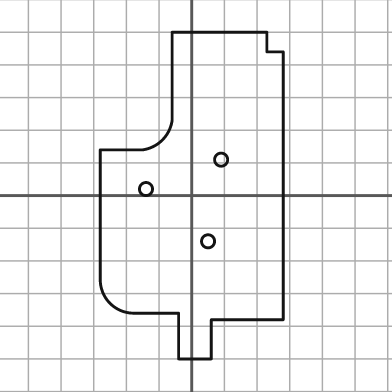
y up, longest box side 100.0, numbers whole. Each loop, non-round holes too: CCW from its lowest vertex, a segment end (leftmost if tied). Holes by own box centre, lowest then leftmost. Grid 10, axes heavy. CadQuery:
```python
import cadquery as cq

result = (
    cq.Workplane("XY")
    .moveTo(-4.0, -50.0)
    .lineTo(6.0, -50.0)
    .lineTo(6.0, -38.0)
    .lineTo(28.0, -38.0)
    .lineTo(28.0, 44.0)
    .lineTo(23.0, 44.0)
    .lineTo(23.0, 50.0)
    .lineTo(-6.0, 50.0)
    .lineTo(-6.0, 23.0)
    .threePointArc((-9.0, 17.0), (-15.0, 14.0))
    .lineTo(-28.0, 14.0)
    .lineTo(-28.0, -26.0)
    .threePointArc((-25.0, -33.0), (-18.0, -36.0))
    .lineTo(-4.0, -36.0)
    .close()
    .moveTo(5.0, -14.0)
    .circle(2.0)
    .moveTo(-14.0, 2.0)
    .circle(2.0)
    .moveTo(9.0, 11.0)
    .circle(2.0)
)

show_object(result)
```